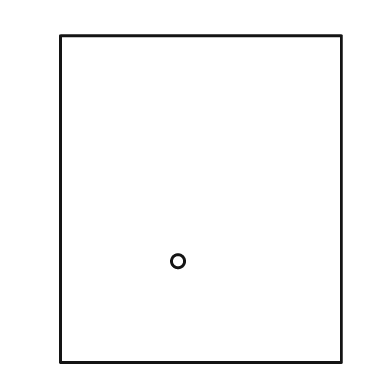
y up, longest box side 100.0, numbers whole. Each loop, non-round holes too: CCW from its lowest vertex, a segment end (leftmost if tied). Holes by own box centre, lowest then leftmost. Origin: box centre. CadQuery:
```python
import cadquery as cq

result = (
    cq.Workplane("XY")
    .moveTo(-43.0, -50.0)
    .lineTo(43.0, -50.0)
    .lineTo(43.0, 50.0)
    .lineTo(-43.0, 50.0)
    .close()
    .moveTo(-7.0, -19.0)
    .circle(2.0)
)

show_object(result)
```